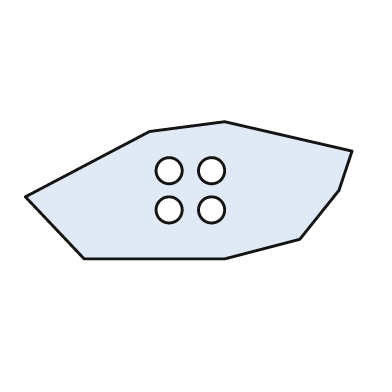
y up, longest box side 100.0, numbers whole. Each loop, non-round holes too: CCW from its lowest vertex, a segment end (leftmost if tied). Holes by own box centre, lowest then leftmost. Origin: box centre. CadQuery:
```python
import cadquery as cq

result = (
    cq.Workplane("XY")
    .moveTo(-32.0, -21.0)
    .lineTo(11.0, -21.0)
    .lineTo(34.0, -15.0)
    .lineTo(46.0, 0.0)
    .lineTo(50.0, 12.0)
    .lineTo(11.0, 21.0)
    .lineTo(-12.0, 18.0)
    .lineTo(-50.0, -2.0)
    .close()
    .moveTo(-6.0, -6.0)
    .circle(4.0)
    .moveTo(7.0, -6.0)
    .circle(4.0)
    .moveTo(-6.0, 6.0)
    .circle(4.0)
    .moveTo(7.0, 6.0)
    .circle(4.0)
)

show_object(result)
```